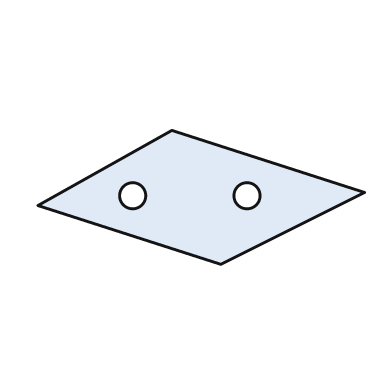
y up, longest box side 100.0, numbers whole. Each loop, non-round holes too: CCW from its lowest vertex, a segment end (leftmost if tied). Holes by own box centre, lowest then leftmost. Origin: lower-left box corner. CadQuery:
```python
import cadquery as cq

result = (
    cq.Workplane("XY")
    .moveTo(56.0, 0.0)
    .lineTo(100.0, 22.0)
    .lineTo(41.0, 41.0)
    .lineTo(0.0, 18.0)
    .close()
    .moveTo(29.0, 21.0)
    .circle(4.0)
    .moveTo(64.0, 21.0)
    .circle(4.0)
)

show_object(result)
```